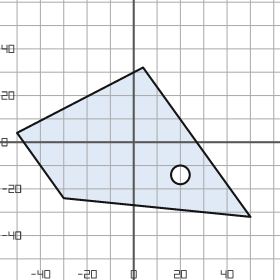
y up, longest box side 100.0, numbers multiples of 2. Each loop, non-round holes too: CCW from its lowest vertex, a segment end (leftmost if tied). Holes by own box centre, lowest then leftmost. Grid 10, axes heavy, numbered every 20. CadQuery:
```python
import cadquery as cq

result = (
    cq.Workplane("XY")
    .moveTo(50.0, -32.0)
    .lineTo(4.0, 32.0)
    .lineTo(-50.0, 4.0)
    .lineTo(-30.0, -24.0)
    .close()
    .moveTo(20.0, -14.0)
    .circle(4.0)
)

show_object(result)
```